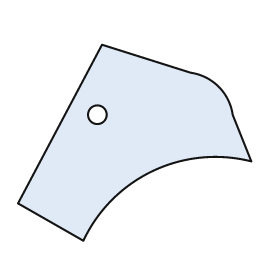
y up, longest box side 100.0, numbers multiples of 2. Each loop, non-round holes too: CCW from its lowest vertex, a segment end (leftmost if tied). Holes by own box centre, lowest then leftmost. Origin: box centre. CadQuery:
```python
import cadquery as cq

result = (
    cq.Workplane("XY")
    .moveTo(-22.0, -42.0)
    .threePointArc((8.0, -12.0), (50.0, -8.0))
    .lineTo(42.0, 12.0)
    .threePointArc((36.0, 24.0), (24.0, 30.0))
    .lineTo(-14.0, 42.0)
    .lineTo(-50.0, -26.0)
    .close()
    .moveTo(-16.0, 12.0)
    .circle(4.0)
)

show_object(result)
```